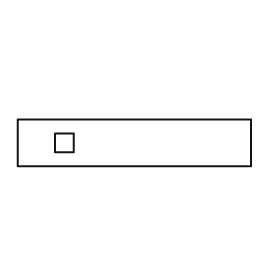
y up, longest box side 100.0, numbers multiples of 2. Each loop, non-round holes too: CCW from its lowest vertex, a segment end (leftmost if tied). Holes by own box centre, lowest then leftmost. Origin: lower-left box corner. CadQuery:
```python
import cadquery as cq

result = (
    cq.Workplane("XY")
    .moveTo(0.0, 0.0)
    .lineTo(100.0, 0.0)
    .lineTo(100.0, 20.0)
    .lineTo(0.0, 20.0)
    .close()
    .moveTo(16.0, 6.0)
    .lineTo(24.0, 6.0)
    .lineTo(24.0, 14.0)
    .lineTo(16.0, 14.0)
    .close()
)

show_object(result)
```